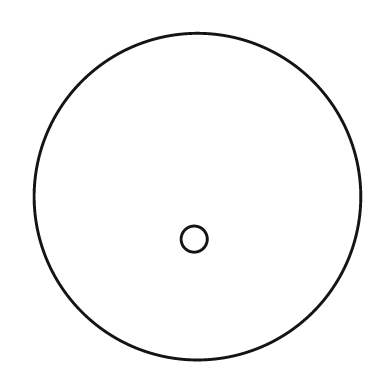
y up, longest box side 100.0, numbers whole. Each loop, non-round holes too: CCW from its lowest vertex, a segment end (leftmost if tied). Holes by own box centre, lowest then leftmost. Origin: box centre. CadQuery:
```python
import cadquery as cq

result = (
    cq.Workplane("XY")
    .moveTo(0.0, 0.0)
    .circle(50.0)
    .moveTo(-1.0, -13.0)
    .circle(4.0)
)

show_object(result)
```